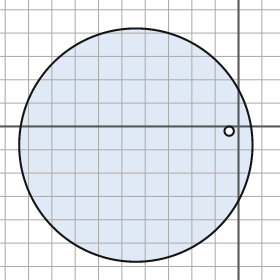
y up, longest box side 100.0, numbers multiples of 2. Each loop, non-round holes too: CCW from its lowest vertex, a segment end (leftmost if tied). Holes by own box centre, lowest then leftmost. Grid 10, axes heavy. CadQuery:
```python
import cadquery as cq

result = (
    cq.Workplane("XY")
    .moveTo(-44.0, -8.0)
    .circle(50.0)
    .moveTo(-4.0, -2.0)
    .circle(2.0)
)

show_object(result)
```